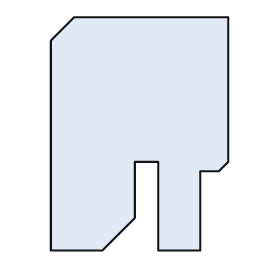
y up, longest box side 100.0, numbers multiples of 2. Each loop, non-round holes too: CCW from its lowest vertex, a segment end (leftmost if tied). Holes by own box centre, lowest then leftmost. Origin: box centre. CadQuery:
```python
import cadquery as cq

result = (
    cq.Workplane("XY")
    .moveTo(-38.0, -50.0)
    .lineTo(-16.0, -50.0)
    .lineTo(-2.0, -36.0)
    .lineTo(-2.0, -12.0)
    .lineTo(8.0, -12.0)
    .lineTo(8.0, -50.0)
    .lineTo(26.0, -50.0)
    .lineTo(26.0, -16.0)
    .lineTo(34.0, -16.0)
    .lineTo(38.0, -12.0)
    .lineTo(38.0, 50.0)
    .lineTo(-28.0, 50.0)
    .lineTo(-38.0, 40.0)
    .close()
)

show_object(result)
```